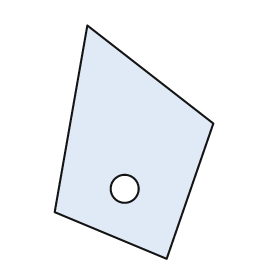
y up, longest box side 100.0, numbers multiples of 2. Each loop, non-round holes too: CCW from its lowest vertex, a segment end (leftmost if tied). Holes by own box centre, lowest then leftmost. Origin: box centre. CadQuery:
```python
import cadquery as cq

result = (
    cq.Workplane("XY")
    .moveTo(14.0, -50.0)
    .lineTo(34.0, 8.0)
    .lineTo(-20.0, 50.0)
    .lineTo(-34.0, -30.0)
    .close()
    .moveTo(-4.0, -20.0)
    .circle(6.0)
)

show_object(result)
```